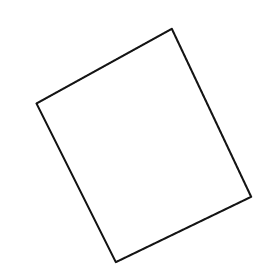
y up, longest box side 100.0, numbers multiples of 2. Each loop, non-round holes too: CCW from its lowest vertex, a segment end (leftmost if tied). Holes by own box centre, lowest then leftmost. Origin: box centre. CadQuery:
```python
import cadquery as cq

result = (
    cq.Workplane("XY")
    .moveTo(-12.0, -50.0)
    .lineTo(46.0, -22.0)
    .lineTo(12.0, 50.0)
    .lineTo(-46.0, 18.0)
    .close()
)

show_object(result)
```